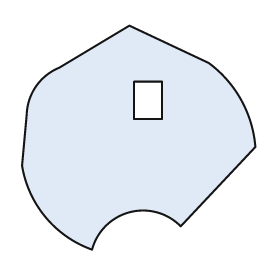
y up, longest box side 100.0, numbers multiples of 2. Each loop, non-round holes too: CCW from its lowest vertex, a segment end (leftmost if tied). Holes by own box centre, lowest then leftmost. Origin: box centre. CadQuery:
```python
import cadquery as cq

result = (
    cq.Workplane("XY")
    .moveTo(-20.0, -48.0)
    .threePointArc((-4.0, -32.0), (18.0, -38.0))
    .lineTo(50.0, -4.0)
    .threePointArc((44.0, 16.0), (30.0, 32.0))
    .lineTo(-4.0, 48.0)
    .lineTo(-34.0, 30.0)
    .threePointArc((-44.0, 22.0), (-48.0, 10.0))
    .lineTo(-50.0, -12.0)
    .threePointArc((-40.0, -34.0), (-20.0, -48.0))
    .close()
    .moveTo(-2.0, 8.0)
    .lineTo(10.0, 8.0)
    .lineTo(10.0, 24.0)
    .lineTo(-2.0, 24.0)
    .close()
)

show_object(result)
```